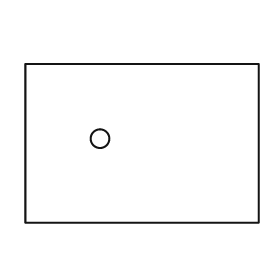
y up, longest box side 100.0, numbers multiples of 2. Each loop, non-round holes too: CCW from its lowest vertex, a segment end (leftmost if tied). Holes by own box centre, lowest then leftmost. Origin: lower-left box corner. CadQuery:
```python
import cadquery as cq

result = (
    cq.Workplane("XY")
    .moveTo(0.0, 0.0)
    .lineTo(100.0, 0.0)
    .lineTo(100.0, 68.0)
    .lineTo(0.0, 68.0)
    .close()
    .moveTo(32.0, 36.0)
    .circle(4.0)
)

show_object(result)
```